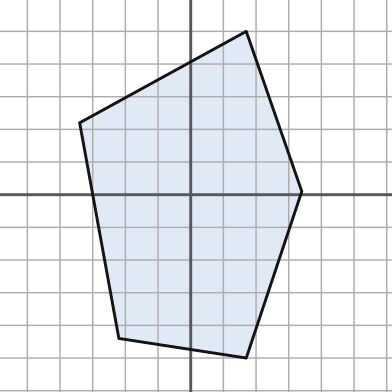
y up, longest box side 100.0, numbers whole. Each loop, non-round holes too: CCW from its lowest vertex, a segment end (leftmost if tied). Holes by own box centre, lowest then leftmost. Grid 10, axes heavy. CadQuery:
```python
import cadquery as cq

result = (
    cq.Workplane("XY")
    .moveTo(17.0, -50.0)
    .lineTo(34.0, 1.0)
    .lineTo(17.0, 50.0)
    .lineTo(-34.0, 22.0)
    .lineTo(-22.0, -44.0)
    .close()
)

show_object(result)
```